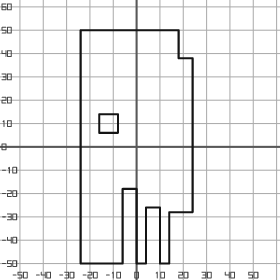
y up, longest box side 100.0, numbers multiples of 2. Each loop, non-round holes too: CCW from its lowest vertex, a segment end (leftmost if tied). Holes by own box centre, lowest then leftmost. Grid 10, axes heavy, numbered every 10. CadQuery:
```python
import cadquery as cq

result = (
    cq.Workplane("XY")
    .moveTo(-24.0, -50.0)
    .lineTo(-6.0, -50.0)
    .lineTo(-6.0, -18.0)
    .lineTo(0.0, -18.0)
    .lineTo(0.0, -50.0)
    .lineTo(4.0, -50.0)
    .lineTo(4.0, -26.0)
    .lineTo(10.0, -26.0)
    .lineTo(10.0, -50.0)
    .lineTo(14.0, -50.0)
    .lineTo(14.0, -28.0)
    .lineTo(24.0, -28.0)
    .lineTo(24.0, 38.0)
    .lineTo(18.0, 38.0)
    .lineTo(18.0, 50.0)
    .lineTo(-24.0, 50.0)
    .close()
    .moveTo(-16.0, 6.0)
    .lineTo(-8.0, 6.0)
    .lineTo(-8.0, 14.0)
    .lineTo(-16.0, 14.0)
    .close()
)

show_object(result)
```